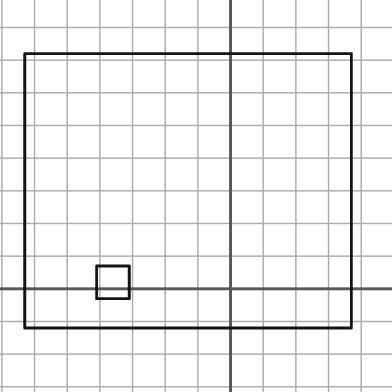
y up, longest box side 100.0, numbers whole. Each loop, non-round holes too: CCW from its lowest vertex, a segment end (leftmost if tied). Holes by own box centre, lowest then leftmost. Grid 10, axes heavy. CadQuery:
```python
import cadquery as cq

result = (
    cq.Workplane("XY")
    .moveTo(-63.0, -12.0)
    .lineTo(37.0, -12.0)
    .lineTo(37.0, 72.0)
    .lineTo(-63.0, 72.0)
    .close()
    .moveTo(-41.0, -3.0)
    .lineTo(-31.0, -3.0)
    .lineTo(-31.0, 7.0)
    .lineTo(-41.0, 7.0)
    .close()
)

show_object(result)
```